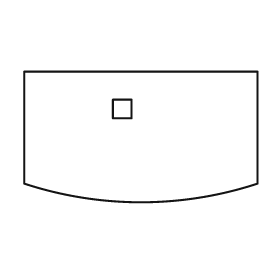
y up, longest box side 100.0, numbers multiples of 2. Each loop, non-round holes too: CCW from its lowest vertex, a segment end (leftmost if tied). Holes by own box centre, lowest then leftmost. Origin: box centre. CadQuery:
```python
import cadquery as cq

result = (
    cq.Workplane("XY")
    .moveTo(-50.0, -20.0)
    .threePointArc((0.0, -28.0), (50.0, -20.0))
    .lineTo(50.0, 28.0)
    .lineTo(-50.0, 28.0)
    .close()
    .moveTo(-12.0, 8.0)
    .lineTo(-4.0, 8.0)
    .lineTo(-4.0, 16.0)
    .lineTo(-12.0, 16.0)
    .close()
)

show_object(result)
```